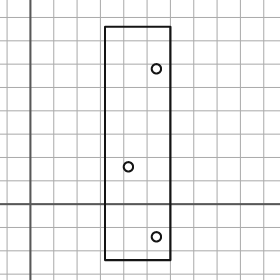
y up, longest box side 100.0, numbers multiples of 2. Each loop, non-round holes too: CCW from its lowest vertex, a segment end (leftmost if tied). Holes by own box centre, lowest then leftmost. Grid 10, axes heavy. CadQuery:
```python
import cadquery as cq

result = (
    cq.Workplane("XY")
    .moveTo(32.0, -24.0)
    .lineTo(60.0, -24.0)
    .lineTo(60.0, 76.0)
    .lineTo(32.0, 76.0)
    .close()
    .moveTo(54.0, -14.0)
    .circle(2.0)
    .moveTo(42.0, 16.0)
    .circle(2.0)
    .moveTo(54.0, 58.0)
    .circle(2.0)
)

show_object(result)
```